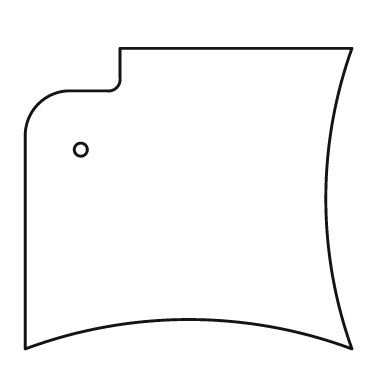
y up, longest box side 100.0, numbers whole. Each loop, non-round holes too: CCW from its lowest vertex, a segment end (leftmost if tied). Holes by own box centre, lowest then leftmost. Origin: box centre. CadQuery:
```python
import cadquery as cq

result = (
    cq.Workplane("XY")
    .moveTo(-50.0, -46.0)
    .threePointArc((0.0, -37.0), (50.0, -46.0))
    .threePointArc((42.0, 0.0), (50.0, 46.0))
    .lineTo(-21.0, 46.0)
    .lineTo(-21.0, 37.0)
    .threePointArc((-22.0, 34.0), (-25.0, 33.0))
    .lineTo(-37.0, 33.0)
    .threePointArc((-46.0, 29.0), (-50.0, 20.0))
    .close()
    .moveTo(-33.0, 15.0)
    .circle(2.0)
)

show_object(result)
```